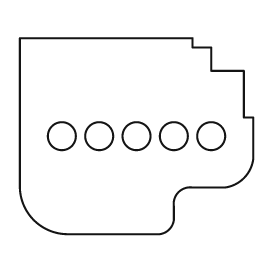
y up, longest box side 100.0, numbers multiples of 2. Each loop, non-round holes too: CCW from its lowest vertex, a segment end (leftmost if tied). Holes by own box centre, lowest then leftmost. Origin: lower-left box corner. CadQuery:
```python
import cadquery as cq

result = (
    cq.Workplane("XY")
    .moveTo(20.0, 0.0)
    .lineTo(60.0, 0.0)
    .threePointArc((64.0, 2.0), (66.0, 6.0))
    .lineTo(66.0, 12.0)
    .threePointArc((68.0, 18.0), (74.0, 20.0))
    .lineTo(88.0, 20.0)
    .threePointArc((96.0, 24.0), (100.0, 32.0))
    .lineTo(100.0, 50.0)
    .lineTo(96.0, 50.0)
    .lineTo(96.0, 70.0)
    .lineTo(82.0, 70.0)
    .lineTo(82.0, 80.0)
    .lineTo(74.0, 80.0)
    .lineTo(74.0, 84.0)
    .lineTo(0.0, 84.0)
    .lineTo(0.0, 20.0)
    .threePointArc((6.0, 6.0), (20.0, 0.0))
    .close()
    .moveTo(18.0, 42.0)
    .circle(6.0)
    .moveTo(34.0, 42.0)
    .circle(6.0)
    .moveTo(50.0, 42.0)
    .circle(6.0)
    .moveTo(66.0, 42.0)
    .circle(6.0)
    .moveTo(82.0, 42.0)
    .circle(6.0)
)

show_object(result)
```